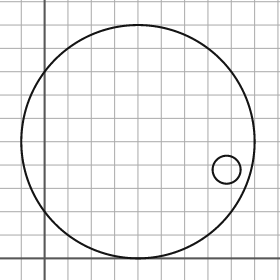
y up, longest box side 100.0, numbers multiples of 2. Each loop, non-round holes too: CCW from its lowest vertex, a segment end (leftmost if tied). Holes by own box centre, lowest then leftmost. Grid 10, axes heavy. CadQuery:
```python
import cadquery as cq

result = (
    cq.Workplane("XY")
    .moveTo(40.0, 50.0)
    .circle(50.0)
    .moveTo(78.0, 38.0)
    .circle(6.0)
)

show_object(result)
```